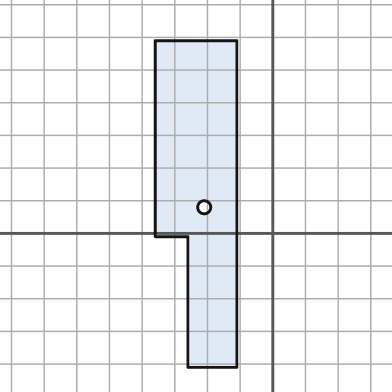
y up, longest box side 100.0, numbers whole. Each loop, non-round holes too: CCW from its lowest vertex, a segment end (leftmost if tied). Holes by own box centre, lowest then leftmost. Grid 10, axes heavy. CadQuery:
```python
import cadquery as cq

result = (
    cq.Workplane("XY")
    .moveTo(-26.0, -41.0)
    .lineTo(-11.0, -41.0)
    .lineTo(-11.0, 59.0)
    .lineTo(-36.0, 59.0)
    .lineTo(-36.0, -1.0)
    .lineTo(-26.0, -1.0)
    .close()
    .moveTo(-21.0, 8.0)
    .circle(2.0)
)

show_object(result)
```